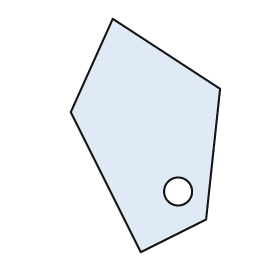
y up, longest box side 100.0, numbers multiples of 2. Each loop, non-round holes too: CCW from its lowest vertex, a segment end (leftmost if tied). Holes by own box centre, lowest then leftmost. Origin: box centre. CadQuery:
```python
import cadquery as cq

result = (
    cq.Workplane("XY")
    .moveTo(-2.0, -50.0)
    .lineTo(26.0, -36.0)
    .lineTo(32.0, 20.0)
    .lineTo(-14.0, 50.0)
    .lineTo(-32.0, 10.0)
    .close()
    .moveTo(14.0, -24.0)
    .circle(6.0)
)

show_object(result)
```